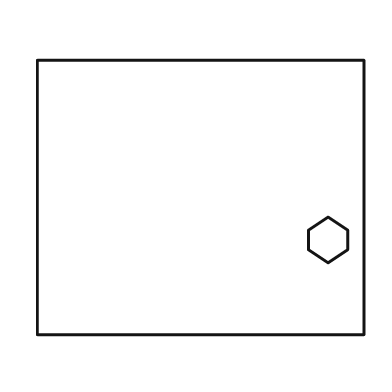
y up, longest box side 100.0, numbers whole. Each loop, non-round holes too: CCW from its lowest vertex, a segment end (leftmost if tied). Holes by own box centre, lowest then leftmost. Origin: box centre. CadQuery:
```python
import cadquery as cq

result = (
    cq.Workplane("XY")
    .moveTo(-50.0, -42.0)
    .lineTo(50.0, -42.0)
    .lineTo(50.0, 42.0)
    .lineTo(-50.0, 42.0)
    .close()
    .moveTo(39.0, -20.0)
    .lineTo(45.0, -16.0)
    .lineTo(45.0, -10.0)
    .lineTo(39.0, -6.0)
    .lineTo(33.0, -10.0)
    .lineTo(33.0, -16.0)
    .close()
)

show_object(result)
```